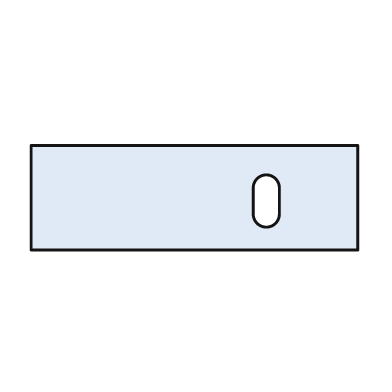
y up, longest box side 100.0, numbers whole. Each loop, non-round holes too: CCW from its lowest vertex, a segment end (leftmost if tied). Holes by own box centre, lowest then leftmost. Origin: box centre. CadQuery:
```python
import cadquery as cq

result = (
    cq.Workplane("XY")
    .moveTo(-50.0, -16.0)
    .lineTo(50.0, -16.0)
    .lineTo(50.0, 16.0)
    .lineTo(-50.0, 16.0)
    .close()
    .moveTo(18.0, -5.0)
    .threePointArc((22.0, -9.0), (26.0, -5.0))
    .lineTo(26.0, 3.0)
    .threePointArc((22.0, 7.0), (18.0, 3.0))
    .close()
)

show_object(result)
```